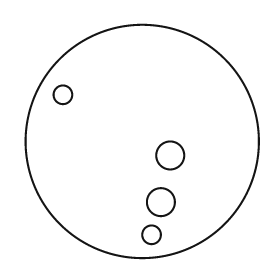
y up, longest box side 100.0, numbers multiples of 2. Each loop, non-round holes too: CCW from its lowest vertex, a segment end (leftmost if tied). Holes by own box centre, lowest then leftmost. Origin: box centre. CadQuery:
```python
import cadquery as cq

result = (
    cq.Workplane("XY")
    .moveTo(0.0, 0.0)
    .circle(50.0)
    .moveTo(4.0, -40.0)
    .circle(4.0)
    .moveTo(8.0, -26.0)
    .circle(6.0)
    .moveTo(12.0, -6.0)
    .circle(6.0)
    .moveTo(-34.0, 20.0)
    .circle(4.0)
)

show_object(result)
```